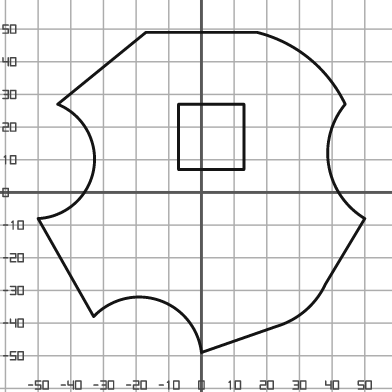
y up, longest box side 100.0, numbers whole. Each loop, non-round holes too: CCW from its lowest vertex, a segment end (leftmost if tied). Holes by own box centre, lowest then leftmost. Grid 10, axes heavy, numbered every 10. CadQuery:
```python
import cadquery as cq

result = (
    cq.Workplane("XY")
    .moveTo(0.0, -49.0)
    .lineTo(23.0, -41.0)
    .threePointArc((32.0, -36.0), (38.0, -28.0))
    .lineTo(50.0, -8.0)
    .threePointArc((39.0, 8.0), (44.0, 27.0))
    .threePointArc((33.0, 41.0), (17.0, 49.0))
    .lineTo(-17.0, 49.0)
    .lineTo(-44.0, 27.0)
    .threePointArc((-33.0, 7.0), (-50.0, -8.0))
    .lineTo(-33.0, -38.0)
    .threePointArc((-13.0, -33.0), (0.0, -49.0))
    .close()
    .moveTo(-7.0, 7.0)
    .lineTo(13.0, 7.0)
    .lineTo(13.0, 27.0)
    .lineTo(-7.0, 27.0)
    .close()
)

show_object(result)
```